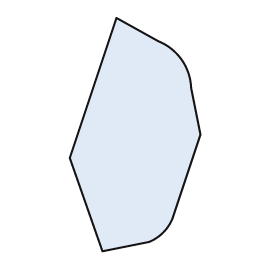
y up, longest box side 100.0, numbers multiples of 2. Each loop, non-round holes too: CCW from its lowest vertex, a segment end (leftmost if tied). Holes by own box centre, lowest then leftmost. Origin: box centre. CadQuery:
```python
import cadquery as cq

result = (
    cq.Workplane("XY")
    .moveTo(-14.0, -50.0)
    .lineTo(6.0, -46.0)
    .threePointArc((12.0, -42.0), (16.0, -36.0))
    .lineTo(28.0, 0.0)
    .lineTo(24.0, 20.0)
    .threePointArc((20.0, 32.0), (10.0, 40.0))
    .lineTo(-8.0, 50.0)
    .lineTo(-28.0, -10.0)
    .close()
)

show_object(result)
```